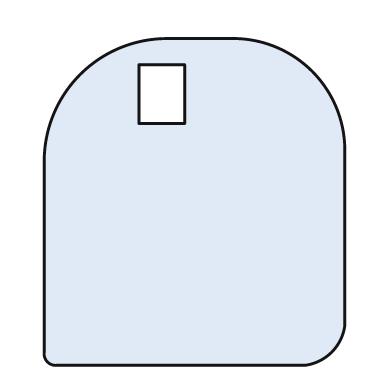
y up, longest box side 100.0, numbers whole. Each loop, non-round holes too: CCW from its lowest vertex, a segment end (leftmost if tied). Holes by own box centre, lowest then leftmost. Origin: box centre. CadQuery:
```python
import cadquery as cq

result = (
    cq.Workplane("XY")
    .moveTo(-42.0, -50.0)
    .lineTo(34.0, -50.0)
    .threePointArc((42.0, -46.0), (46.0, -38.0))
    .lineTo(46.0, 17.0)
    .threePointArc((36.0, 40.0), (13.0, 50.0))
    .lineTo(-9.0, 50.0)
    .threePointArc((-35.0, 39.0), (-46.0, 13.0))
    .lineTo(-46.0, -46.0)
    .threePointArc((-45.0, -49.0), (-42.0, -50.0))
    .close()
    .moveTo(-17.0, 24.0)
    .lineTo(-3.0, 24.0)
    .lineTo(-3.0, 42.0)
    .lineTo(-17.0, 42.0)
    .close()
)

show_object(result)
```